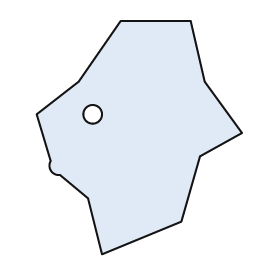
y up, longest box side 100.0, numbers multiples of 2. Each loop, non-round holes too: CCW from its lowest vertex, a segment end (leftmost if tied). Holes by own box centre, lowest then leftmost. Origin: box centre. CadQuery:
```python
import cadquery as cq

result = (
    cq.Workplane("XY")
    .moveTo(-16.0, -50.0)
    .lineTo(18.0, -36.0)
    .lineTo(26.0, -8.0)
    .lineTo(44.0, 2.0)
    .lineTo(28.0, 24.0)
    .lineTo(22.0, 50.0)
    .lineTo(-8.0, 50.0)
    .lineTo(-26.0, 24.0)
    .lineTo(-44.0, 10.0)
    .lineTo(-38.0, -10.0)
    .threePointArc((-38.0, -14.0), (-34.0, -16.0))
    .lineTo(-22.0, -26.0)
    .close()
    .moveTo(-20.0, 10.0)
    .circle(4.0)
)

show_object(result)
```